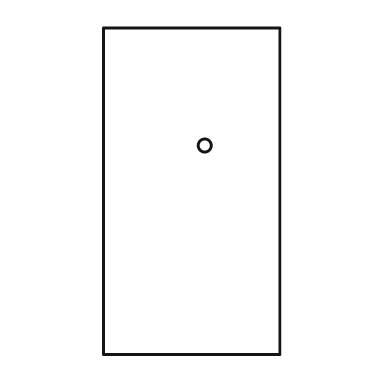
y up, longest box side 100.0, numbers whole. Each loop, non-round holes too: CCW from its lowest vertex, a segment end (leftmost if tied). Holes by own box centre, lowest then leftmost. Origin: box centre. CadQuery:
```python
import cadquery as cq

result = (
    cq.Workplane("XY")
    .moveTo(-27.0, -50.0)
    .lineTo(27.0, -50.0)
    .lineTo(27.0, 50.0)
    .lineTo(-27.0, 50.0)
    .close()
    .moveTo(4.0, 14.0)
    .circle(2.0)
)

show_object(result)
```